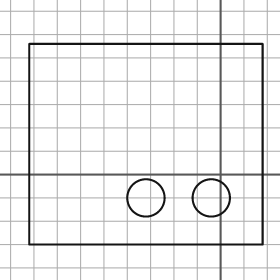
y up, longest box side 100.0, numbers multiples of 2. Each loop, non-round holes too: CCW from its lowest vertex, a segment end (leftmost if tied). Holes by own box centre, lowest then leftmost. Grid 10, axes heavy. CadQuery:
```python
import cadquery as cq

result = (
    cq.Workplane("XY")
    .moveTo(-82.0, -30.0)
    .lineTo(18.0, -30.0)
    .lineTo(18.0, 56.0)
    .lineTo(-82.0, 56.0)
    .close()
    .moveTo(-32.0, -10.0)
    .circle(8.0)
    .moveTo(-4.0, -10.0)
    .circle(8.0)
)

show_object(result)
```